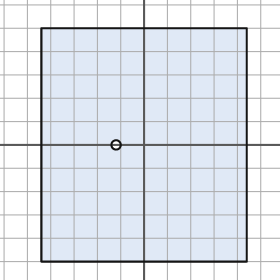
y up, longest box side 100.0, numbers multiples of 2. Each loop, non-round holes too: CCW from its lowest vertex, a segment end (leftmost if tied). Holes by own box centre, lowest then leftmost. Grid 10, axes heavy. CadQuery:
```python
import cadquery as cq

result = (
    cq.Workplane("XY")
    .moveTo(-44.0, -50.0)
    .lineTo(44.0, -50.0)
    .lineTo(44.0, 50.0)
    .lineTo(-44.0, 50.0)
    .close()
    .moveTo(-12.0, 0.0)
    .circle(2.0)
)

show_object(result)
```